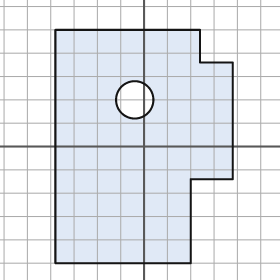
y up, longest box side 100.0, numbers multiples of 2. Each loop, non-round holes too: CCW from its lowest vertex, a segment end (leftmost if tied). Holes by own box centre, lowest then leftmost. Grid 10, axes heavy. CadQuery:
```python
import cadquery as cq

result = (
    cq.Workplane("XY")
    .moveTo(-38.0, -50.0)
    .lineTo(20.0, -50.0)
    .lineTo(20.0, -14.0)
    .lineTo(38.0, -14.0)
    .lineTo(38.0, 36.0)
    .lineTo(24.0, 36.0)
    .lineTo(24.0, 50.0)
    .lineTo(-38.0, 50.0)
    .close()
    .moveTo(-4.0, 20.0)
    .circle(8.0)
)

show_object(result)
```